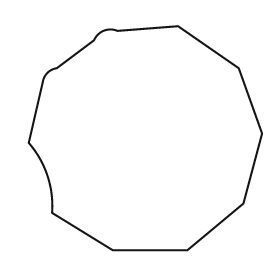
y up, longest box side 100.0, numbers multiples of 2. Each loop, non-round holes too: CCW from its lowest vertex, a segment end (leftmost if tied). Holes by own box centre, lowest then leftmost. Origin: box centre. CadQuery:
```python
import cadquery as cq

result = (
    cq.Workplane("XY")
    .moveTo(-14.0, -48.0)
    .lineTo(18.0, -48.0)
    .lineTo(42.0, -28.0)
    .lineTo(50.0, 2.0)
    .lineTo(40.0, 30.0)
    .lineTo(14.0, 48.0)
    .lineTo(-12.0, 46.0)
    .threePointArc((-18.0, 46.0), (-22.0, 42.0))
    .lineTo(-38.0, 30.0)
    .threePointArc((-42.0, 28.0), (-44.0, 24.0))
    .lineTo(-50.0, -2.0)
    .threePointArc((-42.0, -16.0), (-40.0, -32.0))
    .close()
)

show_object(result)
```